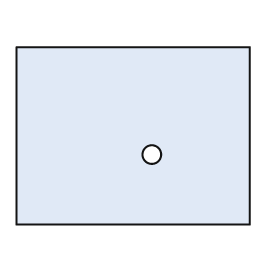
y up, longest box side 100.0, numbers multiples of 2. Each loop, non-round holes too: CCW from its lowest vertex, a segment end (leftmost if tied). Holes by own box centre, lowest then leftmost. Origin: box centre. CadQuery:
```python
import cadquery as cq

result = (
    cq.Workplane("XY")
    .moveTo(-50.0, -38.0)
    .lineTo(50.0, -38.0)
    .lineTo(50.0, 38.0)
    .lineTo(-50.0, 38.0)
    .close()
    .moveTo(8.0, -8.0)
    .circle(4.0)
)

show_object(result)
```